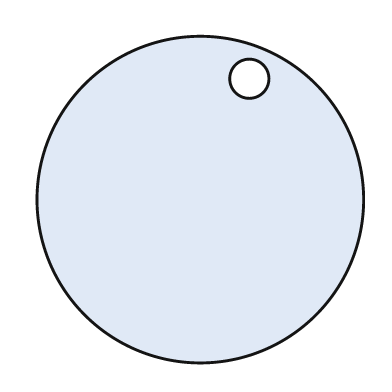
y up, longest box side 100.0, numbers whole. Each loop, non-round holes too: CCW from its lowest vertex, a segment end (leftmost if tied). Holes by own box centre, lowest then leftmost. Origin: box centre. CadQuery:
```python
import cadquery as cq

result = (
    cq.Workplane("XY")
    .moveTo(0.0, 0.0)
    .circle(50.0)
    .moveTo(15.0, 37.0)
    .circle(6.0)
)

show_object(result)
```